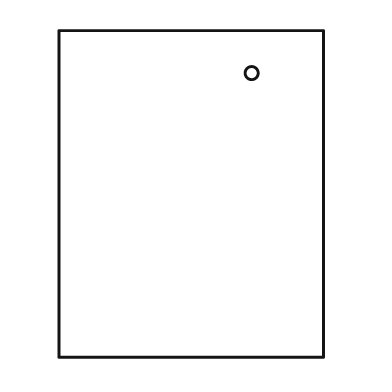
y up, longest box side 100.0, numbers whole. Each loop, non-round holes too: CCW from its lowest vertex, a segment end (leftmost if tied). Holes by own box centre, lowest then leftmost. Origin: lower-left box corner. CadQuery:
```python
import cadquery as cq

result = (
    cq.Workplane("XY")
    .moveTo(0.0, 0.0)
    .lineTo(81.0, 0.0)
    .lineTo(81.0, 100.0)
    .lineTo(0.0, 100.0)
    .close()
    .moveTo(59.0, 87.0)
    .circle(2.0)
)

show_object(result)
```